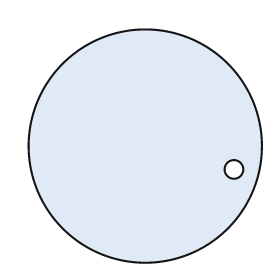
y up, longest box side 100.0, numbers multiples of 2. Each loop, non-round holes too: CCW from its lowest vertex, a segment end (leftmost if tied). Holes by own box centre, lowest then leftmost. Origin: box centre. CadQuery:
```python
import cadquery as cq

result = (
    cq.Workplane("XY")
    .moveTo(0.0, 0.0)
    .circle(50.0)
    .moveTo(38.0, -10.0)
    .circle(4.0)
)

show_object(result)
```